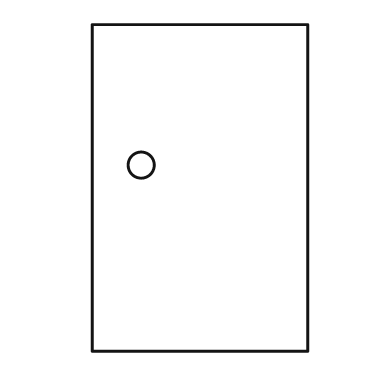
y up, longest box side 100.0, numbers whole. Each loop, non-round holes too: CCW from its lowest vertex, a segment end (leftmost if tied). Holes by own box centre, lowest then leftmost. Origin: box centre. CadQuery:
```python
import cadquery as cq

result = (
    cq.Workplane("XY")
    .moveTo(-33.0, -50.0)
    .lineTo(33.0, -50.0)
    .lineTo(33.0, 50.0)
    .lineTo(-33.0, 50.0)
    .close()
    .moveTo(-18.0, 7.0)
    .circle(4.0)
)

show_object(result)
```